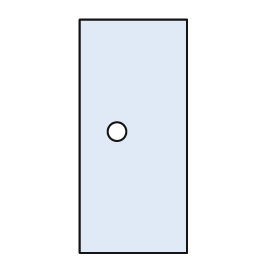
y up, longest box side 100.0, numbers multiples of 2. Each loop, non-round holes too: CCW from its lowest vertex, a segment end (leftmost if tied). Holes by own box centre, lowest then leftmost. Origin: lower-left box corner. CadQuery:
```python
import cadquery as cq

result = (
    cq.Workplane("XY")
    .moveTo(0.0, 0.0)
    .lineTo(46.0, 0.0)
    .lineTo(46.0, 100.0)
    .lineTo(0.0, 100.0)
    .close()
    .moveTo(16.0, 52.0)
    .circle(4.0)
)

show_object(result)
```